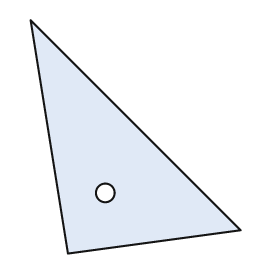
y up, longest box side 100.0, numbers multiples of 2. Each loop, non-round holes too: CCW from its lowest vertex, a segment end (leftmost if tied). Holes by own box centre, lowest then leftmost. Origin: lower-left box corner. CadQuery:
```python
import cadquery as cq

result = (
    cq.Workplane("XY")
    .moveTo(16.0, 0.0)
    .lineTo(90.0, 10.0)
    .lineTo(0.0, 100.0)
    .close()
    .moveTo(32.0, 26.0)
    .circle(4.0)
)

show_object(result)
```